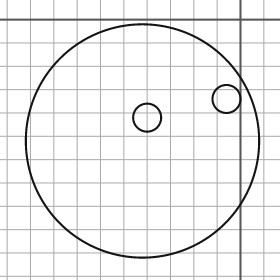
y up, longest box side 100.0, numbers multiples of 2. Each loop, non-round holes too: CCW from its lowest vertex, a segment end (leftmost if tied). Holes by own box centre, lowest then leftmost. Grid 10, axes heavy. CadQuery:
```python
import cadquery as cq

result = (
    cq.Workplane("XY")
    .moveTo(-42.0, -52.0)
    .circle(50.0)
    .moveTo(-40.0, -42.0)
    .circle(6.0)
    .moveTo(-6.0, -34.0)
    .circle(6.0)
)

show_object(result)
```